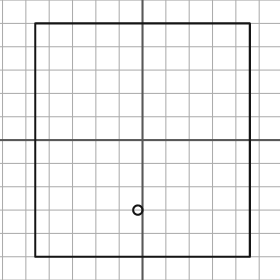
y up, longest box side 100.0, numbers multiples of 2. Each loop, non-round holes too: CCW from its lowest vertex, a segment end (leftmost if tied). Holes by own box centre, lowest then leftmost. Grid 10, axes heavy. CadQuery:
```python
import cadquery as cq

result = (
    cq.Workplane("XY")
    .moveTo(-46.0, -50.0)
    .lineTo(46.0, -50.0)
    .lineTo(46.0, 50.0)
    .lineTo(-46.0, 50.0)
    .close()
    .moveTo(-2.0, -30.0)
    .circle(2.0)
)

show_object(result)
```